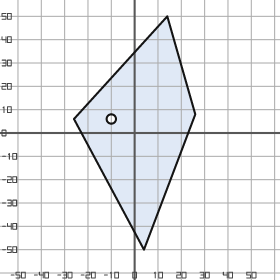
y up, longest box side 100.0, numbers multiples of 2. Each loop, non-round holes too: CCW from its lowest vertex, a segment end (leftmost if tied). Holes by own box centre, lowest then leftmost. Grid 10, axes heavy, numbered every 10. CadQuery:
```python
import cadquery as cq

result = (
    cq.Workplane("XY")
    .moveTo(4.0, -50.0)
    .lineTo(26.0, 8.0)
    .lineTo(14.0, 50.0)
    .lineTo(-26.0, 6.0)
    .close()
    .moveTo(-10.0, 6.0)
    .circle(2.0)
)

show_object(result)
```